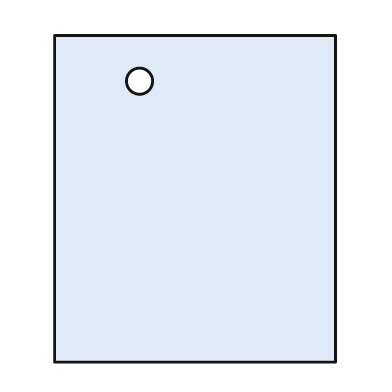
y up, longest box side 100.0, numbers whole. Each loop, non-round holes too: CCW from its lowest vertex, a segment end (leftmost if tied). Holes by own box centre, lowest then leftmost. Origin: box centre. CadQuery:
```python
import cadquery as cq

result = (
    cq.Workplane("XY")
    .moveTo(-43.0, -50.0)
    .lineTo(43.0, -50.0)
    .lineTo(43.0, 50.0)
    .lineTo(-43.0, 50.0)
    .close()
    .moveTo(-17.0, 36.0)
    .circle(4.0)
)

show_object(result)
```